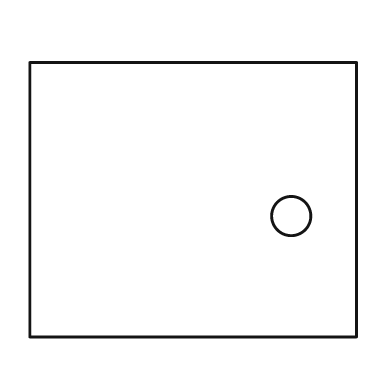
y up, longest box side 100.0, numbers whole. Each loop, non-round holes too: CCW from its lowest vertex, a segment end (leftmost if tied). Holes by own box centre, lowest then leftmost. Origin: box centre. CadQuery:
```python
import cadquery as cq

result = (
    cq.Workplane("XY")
    .moveTo(-50.0, -42.0)
    .lineTo(50.0, -42.0)
    .lineTo(50.0, 42.0)
    .lineTo(-50.0, 42.0)
    .close()
    .moveTo(30.0, -5.0)
    .circle(6.0)
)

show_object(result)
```